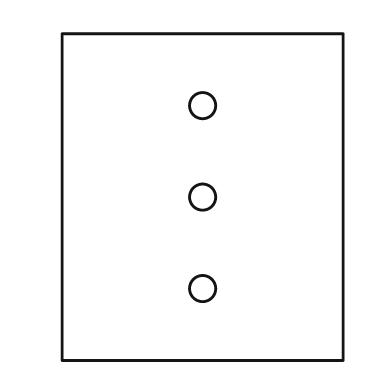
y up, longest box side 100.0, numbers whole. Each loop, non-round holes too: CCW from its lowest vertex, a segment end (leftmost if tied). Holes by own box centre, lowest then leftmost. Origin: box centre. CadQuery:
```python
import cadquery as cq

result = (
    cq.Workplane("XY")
    .moveTo(-43.0, -50.0)
    .lineTo(43.0, -50.0)
    .lineTo(43.0, 50.0)
    .lineTo(-43.0, 50.0)
    .close()
    .moveTo(0.0, -28.0)
    .circle(4.0)
    .moveTo(0.0, 0.0)
    .circle(4.0)
    .moveTo(0.0, 28.0)
    .circle(4.0)
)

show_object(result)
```